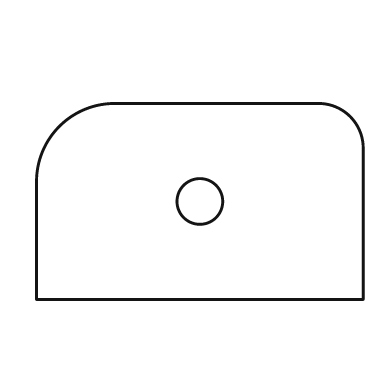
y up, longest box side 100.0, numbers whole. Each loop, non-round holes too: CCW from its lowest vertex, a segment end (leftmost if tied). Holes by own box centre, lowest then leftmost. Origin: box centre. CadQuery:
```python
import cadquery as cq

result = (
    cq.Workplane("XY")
    .moveTo(-50.0, -30.0)
    .lineTo(50.0, -30.0)
    .lineTo(50.0, 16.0)
    .threePointArc((46.0, 26.0), (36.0, 30.0))
    .lineTo(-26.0, 30.0)
    .threePointArc((-43.0, 23.0), (-50.0, 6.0))
    .close()
    .moveTo(0.0, 0.0)
    .circle(7.0)
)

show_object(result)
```